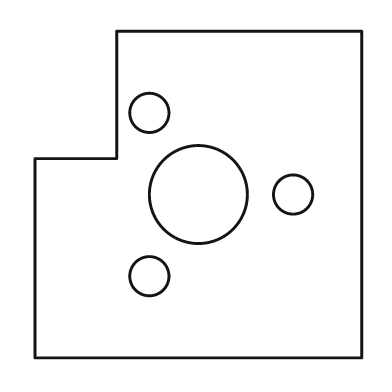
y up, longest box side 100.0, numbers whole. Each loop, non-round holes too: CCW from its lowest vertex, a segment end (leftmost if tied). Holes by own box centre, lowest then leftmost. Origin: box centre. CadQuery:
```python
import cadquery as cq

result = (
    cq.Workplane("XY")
    .moveTo(-50.0, -50.0)
    .lineTo(50.0, -50.0)
    .lineTo(50.0, 50.0)
    .lineTo(-25.0, 50.0)
    .lineTo(-25.0, 11.0)
    .lineTo(-50.0, 11.0)
    .close()
    .moveTo(-15.0, -25.0)
    .circle(6.0)
    .moveTo(0.0, 0.0)
    .circle(15.0)
    .moveTo(29.0, 0.0)
    .circle(6.0)
    .moveTo(-15.0, 25.0)
    .circle(6.0)
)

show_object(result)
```